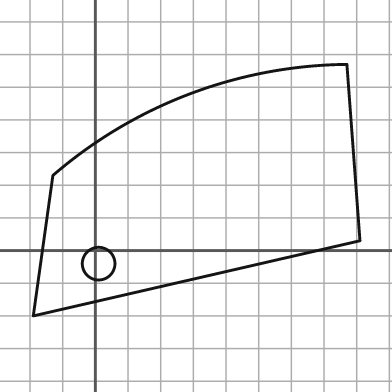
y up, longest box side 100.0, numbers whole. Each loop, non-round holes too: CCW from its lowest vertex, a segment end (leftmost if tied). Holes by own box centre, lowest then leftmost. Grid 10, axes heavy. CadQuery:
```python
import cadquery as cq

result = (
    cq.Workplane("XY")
    .moveTo(-19.0, -20.0)
    .lineTo(81.0, 3.0)
    .lineTo(77.0, 57.0)
    .threePointArc((29.0, 48.0), (-13.0, 23.0))
    .close()
    .moveTo(1.0, -4.0)
    .circle(5.0)
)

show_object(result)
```